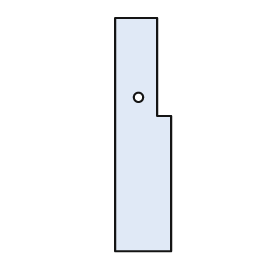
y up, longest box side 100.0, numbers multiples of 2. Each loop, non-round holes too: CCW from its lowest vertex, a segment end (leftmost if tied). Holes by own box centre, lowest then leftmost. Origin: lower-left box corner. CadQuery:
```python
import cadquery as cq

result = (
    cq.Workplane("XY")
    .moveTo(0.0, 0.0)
    .lineTo(24.0, 0.0)
    .lineTo(24.0, 58.0)
    .lineTo(18.0, 58.0)
    .lineTo(18.0, 100.0)
    .lineTo(0.0, 100.0)
    .close()
    .moveTo(10.0, 66.0)
    .circle(2.0)
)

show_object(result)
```